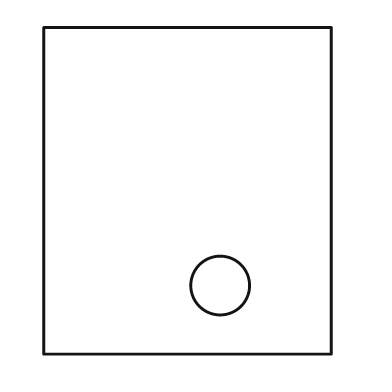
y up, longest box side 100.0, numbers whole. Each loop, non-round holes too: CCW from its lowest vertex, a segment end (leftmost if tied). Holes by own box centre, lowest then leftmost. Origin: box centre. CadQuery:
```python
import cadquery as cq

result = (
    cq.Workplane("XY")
    .moveTo(-44.0, -50.0)
    .lineTo(44.0, -50.0)
    .lineTo(44.0, 50.0)
    .lineTo(-44.0, 50.0)
    .close()
    .moveTo(10.0, -29.0)
    .circle(9.0)
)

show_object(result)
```